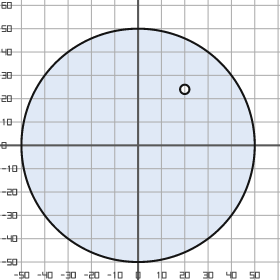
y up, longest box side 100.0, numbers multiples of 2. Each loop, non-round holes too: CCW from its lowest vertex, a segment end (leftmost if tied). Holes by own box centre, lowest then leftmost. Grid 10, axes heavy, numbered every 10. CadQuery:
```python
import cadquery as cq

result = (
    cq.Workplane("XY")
    .moveTo(0.0, 0.0)
    .circle(50.0)
    .moveTo(20.0, 24.0)
    .circle(2.0)
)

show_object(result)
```